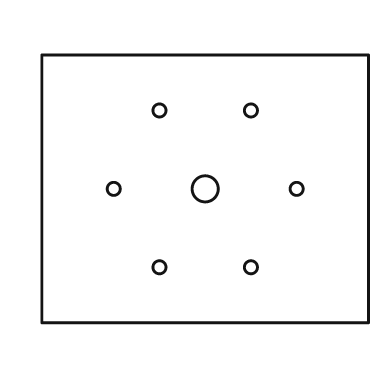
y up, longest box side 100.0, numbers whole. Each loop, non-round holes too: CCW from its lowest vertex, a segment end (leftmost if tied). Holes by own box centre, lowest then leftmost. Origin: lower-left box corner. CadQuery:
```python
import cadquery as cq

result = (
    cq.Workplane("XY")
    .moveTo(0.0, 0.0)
    .lineTo(100.0, 0.0)
    .lineTo(100.0, 82.0)
    .lineTo(0.0, 82.0)
    .close()
    .moveTo(36.0, 17.0)
    .circle(2.0)
    .moveTo(64.0, 17.0)
    .circle(2.0)
    .moveTo(22.0, 41.0)
    .circle(2.0)
    .moveTo(50.0, 41.0)
    .circle(4.0)
    .moveTo(78.0, 41.0)
    .circle(2.0)
    .moveTo(36.0, 65.0)
    .circle(2.0)
    .moveTo(64.0, 65.0)
    .circle(2.0)
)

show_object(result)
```